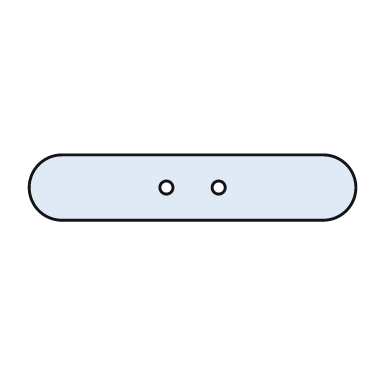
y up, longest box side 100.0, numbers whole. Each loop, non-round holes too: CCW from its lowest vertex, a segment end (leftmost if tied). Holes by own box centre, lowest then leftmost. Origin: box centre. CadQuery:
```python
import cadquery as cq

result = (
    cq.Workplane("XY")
    .moveTo(-40.0, -10.0)
    .lineTo(40.0, -10.0)
    .threePointArc((50.0, 0.0), (40.0, 10.0))
    .lineTo(-40.0, 10.0)
    .threePointArc((-50.0, 0.0), (-40.0, -10.0))
    .close()
    .moveTo(-8.0, 0.0)
    .circle(2.0)
    .moveTo(8.0, 0.0)
    .circle(2.0)
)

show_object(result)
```